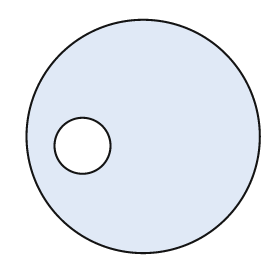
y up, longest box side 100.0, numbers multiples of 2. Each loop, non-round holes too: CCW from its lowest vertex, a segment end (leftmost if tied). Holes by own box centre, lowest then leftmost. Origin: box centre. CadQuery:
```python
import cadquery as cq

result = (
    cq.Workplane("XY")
    .moveTo(0.0, 0.0)
    .circle(50.0)
    .moveTo(-26.0, -4.0)
    .circle(12.0)
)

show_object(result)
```